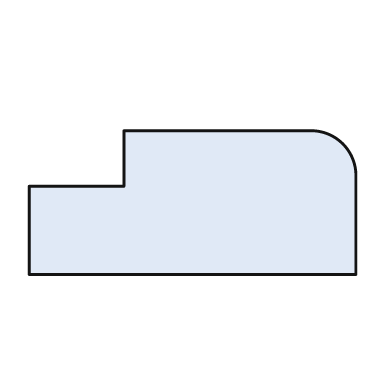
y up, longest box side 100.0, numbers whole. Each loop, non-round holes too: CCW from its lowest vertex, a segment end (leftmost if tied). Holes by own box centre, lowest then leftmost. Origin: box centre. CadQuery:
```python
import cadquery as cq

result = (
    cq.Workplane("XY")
    .moveTo(-50.0, -22.0)
    .lineTo(50.0, -22.0)
    .lineTo(50.0, 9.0)
    .threePointArc((46.0, 18.0), (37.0, 22.0))
    .lineTo(-21.0, 22.0)
    .lineTo(-21.0, 5.0)
    .lineTo(-50.0, 5.0)
    .close()
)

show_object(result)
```